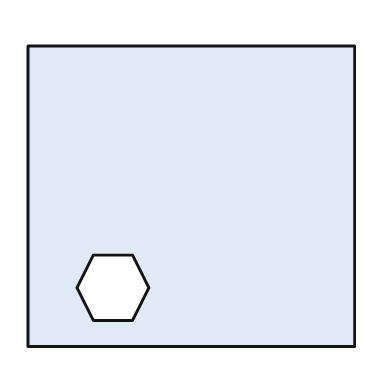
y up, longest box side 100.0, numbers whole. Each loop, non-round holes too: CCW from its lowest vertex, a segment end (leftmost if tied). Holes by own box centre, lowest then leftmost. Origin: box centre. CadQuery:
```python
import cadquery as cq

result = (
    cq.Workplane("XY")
    .moveTo(-50.0, -46.0)
    .lineTo(50.0, -46.0)
    .lineTo(50.0, 46.0)
    .lineTo(-50.0, 46.0)
    .close()
    .moveTo(-30.0, -38.0)
    .lineTo(-18.0, -38.0)
    .lineTo(-13.0, -28.0)
    .lineTo(-18.0, -18.0)
    .lineTo(-30.0, -18.0)
    .lineTo(-35.0, -28.0)
    .close()
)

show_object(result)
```